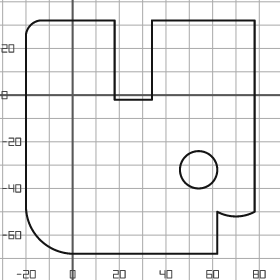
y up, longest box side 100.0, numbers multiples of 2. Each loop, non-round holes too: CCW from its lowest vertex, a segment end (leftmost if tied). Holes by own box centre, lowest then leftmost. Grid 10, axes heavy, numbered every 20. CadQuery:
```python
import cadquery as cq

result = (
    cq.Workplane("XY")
    .moveTo(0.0, -68.0)
    .lineTo(62.0, -68.0)
    .lineTo(62.0, -50.0)
    .threePointArc((70.0, -52.0), (78.0, -50.0))
    .lineTo(78.0, 32.0)
    .lineTo(34.0, 32.0)
    .lineTo(34.0, -2.0)
    .lineTo(18.0, -2.0)
    .lineTo(18.0, 32.0)
    .lineTo(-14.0, 32.0)
    .threePointArc((-18.0, 30.0), (-20.0, 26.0))
    .lineTo(-20.0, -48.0)
    .threePointArc((-14.0, -62.0), (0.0, -68.0))
    .close()
    .moveTo(54.0, -32.0)
    .circle(8.0)
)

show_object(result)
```